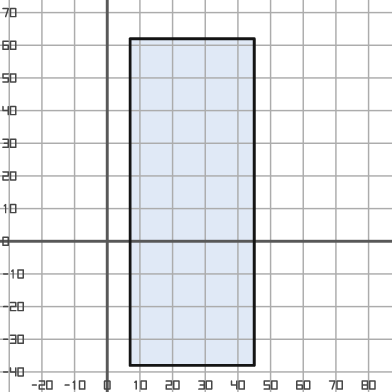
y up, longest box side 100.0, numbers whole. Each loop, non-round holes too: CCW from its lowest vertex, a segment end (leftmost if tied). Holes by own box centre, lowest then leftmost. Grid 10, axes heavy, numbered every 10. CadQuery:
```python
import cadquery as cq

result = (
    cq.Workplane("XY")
    .moveTo(7.0, -38.0)
    .lineTo(45.0, -38.0)
    .lineTo(45.0, 62.0)
    .lineTo(7.0, 62.0)
    .close()
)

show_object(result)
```